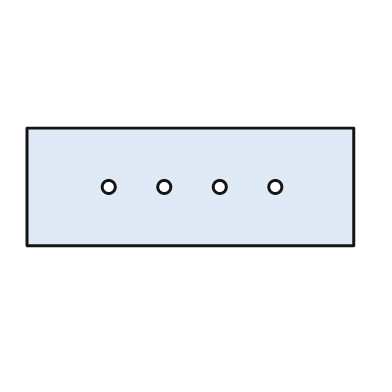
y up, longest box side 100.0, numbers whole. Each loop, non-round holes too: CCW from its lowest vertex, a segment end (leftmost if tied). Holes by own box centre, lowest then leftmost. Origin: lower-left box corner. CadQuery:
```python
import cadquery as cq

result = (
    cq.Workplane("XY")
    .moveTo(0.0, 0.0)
    .lineTo(100.0, 0.0)
    .lineTo(100.0, 36.0)
    .lineTo(0.0, 36.0)
    .close()
    .moveTo(25.0, 18.0)
    .circle(2.0)
    .moveTo(42.0, 18.0)
    .circle(2.0)
    .moveTo(59.0, 18.0)
    .circle(2.0)
    .moveTo(76.0, 18.0)
    .circle(2.0)
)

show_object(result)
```